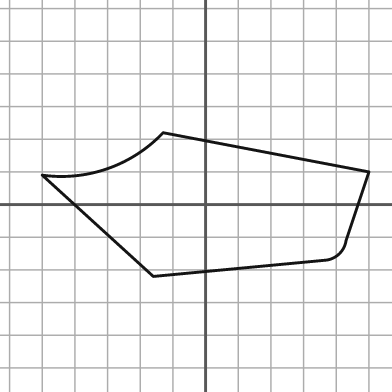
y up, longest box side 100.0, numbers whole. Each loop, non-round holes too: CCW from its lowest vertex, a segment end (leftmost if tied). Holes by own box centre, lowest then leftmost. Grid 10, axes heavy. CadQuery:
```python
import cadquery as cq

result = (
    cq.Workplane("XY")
    .moveTo(-16.0, -22.0)
    .lineTo(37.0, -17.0)
    .threePointArc((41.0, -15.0), (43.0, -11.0))
    .lineTo(50.0, 10.0)
    .lineTo(-13.0, 22.0)
    .threePointArc((-30.0, 11.0), (-50.0, 9.0))
    .close()
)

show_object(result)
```